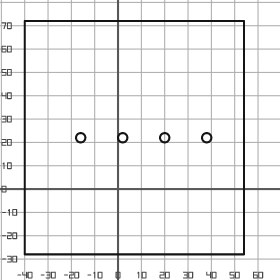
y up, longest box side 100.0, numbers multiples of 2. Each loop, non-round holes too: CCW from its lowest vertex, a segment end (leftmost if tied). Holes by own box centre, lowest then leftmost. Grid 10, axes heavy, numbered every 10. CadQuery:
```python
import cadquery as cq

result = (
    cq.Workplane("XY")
    .moveTo(-40.0, -28.0)
    .lineTo(54.0, -28.0)
    .lineTo(54.0, 72.0)
    .lineTo(-40.0, 72.0)
    .close()
    .moveTo(-16.0, 22.0)
    .circle(2.0)
    .moveTo(2.0, 22.0)
    .circle(2.0)
    .moveTo(20.0, 22.0)
    .circle(2.0)
    .moveTo(38.0, 22.0)
    .circle(2.0)
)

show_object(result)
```